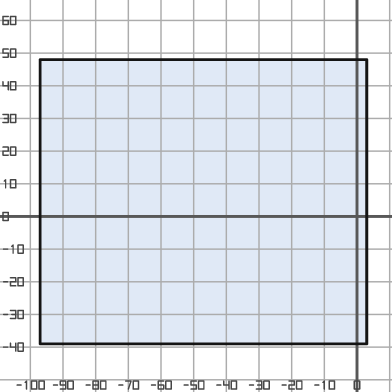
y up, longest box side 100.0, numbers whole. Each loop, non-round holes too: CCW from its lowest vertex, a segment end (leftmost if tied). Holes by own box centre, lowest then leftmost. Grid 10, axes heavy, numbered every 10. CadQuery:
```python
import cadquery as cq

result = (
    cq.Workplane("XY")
    .moveTo(-97.0, -39.0)
    .lineTo(3.0, -39.0)
    .lineTo(3.0, 48.0)
    .lineTo(-97.0, 48.0)
    .close()
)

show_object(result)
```